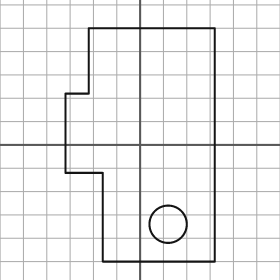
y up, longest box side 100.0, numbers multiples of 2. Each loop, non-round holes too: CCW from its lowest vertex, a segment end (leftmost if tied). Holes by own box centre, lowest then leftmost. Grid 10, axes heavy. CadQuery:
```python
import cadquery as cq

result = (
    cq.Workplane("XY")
    .moveTo(-16.0, -50.0)
    .lineTo(32.0, -50.0)
    .lineTo(32.0, 50.0)
    .lineTo(-22.0, 50.0)
    .lineTo(-22.0, 22.0)
    .lineTo(-32.0, 22.0)
    .lineTo(-32.0, -12.0)
    .lineTo(-16.0, -12.0)
    .close()
    .moveTo(12.0, -34.0)
    .circle(8.0)
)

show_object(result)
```